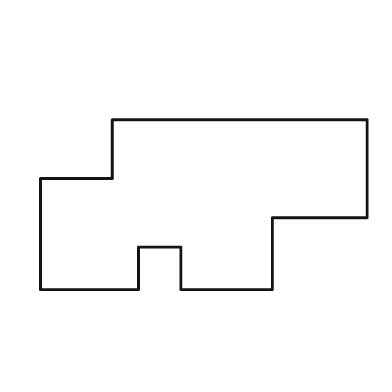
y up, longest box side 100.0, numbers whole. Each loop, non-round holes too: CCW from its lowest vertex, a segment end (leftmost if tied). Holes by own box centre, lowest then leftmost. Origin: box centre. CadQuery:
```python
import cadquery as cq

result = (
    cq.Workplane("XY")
    .moveTo(-50.0, -26.0)
    .lineTo(-20.0, -26.0)
    .lineTo(-20.0, -13.0)
    .lineTo(-7.0, -13.0)
    .lineTo(-7.0, -26.0)
    .lineTo(21.0, -26.0)
    .lineTo(21.0, -4.0)
    .lineTo(50.0, -4.0)
    .lineTo(50.0, 26.0)
    .lineTo(-28.0, 26.0)
    .lineTo(-28.0, 8.0)
    .lineTo(-50.0, 8.0)
    .close()
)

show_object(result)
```